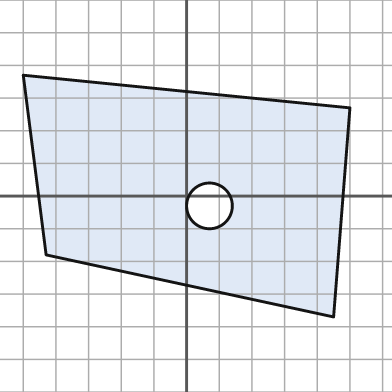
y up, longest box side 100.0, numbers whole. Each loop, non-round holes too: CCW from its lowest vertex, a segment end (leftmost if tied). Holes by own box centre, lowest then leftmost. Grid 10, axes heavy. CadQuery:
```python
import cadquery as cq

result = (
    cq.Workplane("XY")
    .moveTo(45.0, -37.0)
    .lineTo(50.0, 27.0)
    .lineTo(-50.0, 37.0)
    .lineTo(-43.0, -18.0)
    .close()
    .moveTo(7.0, -3.0)
    .circle(7.0)
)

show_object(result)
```